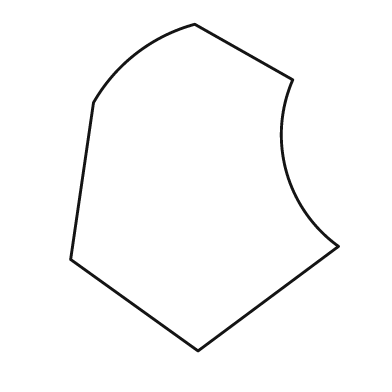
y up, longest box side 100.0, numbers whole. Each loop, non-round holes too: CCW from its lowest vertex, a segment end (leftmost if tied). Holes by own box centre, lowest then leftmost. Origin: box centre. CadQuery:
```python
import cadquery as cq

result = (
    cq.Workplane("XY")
    .moveTo(-2.0, -50.0)
    .lineTo(41.0, -18.0)
    .threePointArc((25.0, 5.0), (27.0, 33.0))
    .lineTo(-3.0, 50.0)
    .threePointArc((-21.0, 41.0), (-34.0, 26.0))
    .lineTo(-41.0, -22.0)
    .close()
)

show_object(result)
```